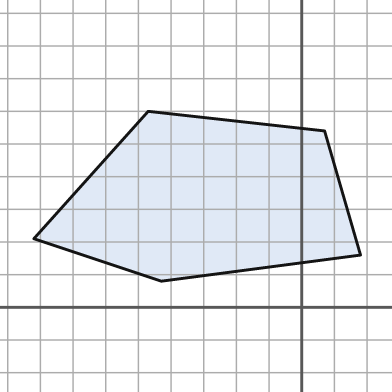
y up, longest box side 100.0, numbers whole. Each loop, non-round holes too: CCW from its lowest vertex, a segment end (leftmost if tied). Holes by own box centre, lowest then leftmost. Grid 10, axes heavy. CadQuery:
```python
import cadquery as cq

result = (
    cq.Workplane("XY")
    .moveTo(-43.0, 8.0)
    .lineTo(18.0, 16.0)
    .lineTo(7.0, 54.0)
    .lineTo(-47.0, 60.0)
    .lineTo(-82.0, 21.0)
    .close()
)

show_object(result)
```